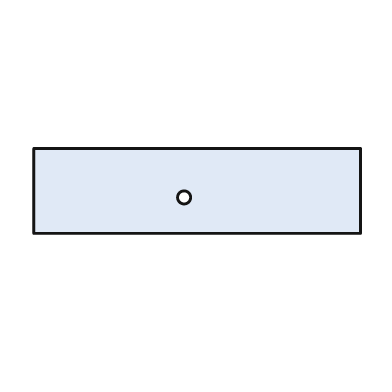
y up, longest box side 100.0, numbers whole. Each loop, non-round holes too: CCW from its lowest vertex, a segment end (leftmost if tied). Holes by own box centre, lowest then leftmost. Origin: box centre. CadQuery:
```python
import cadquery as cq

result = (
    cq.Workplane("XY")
    .moveTo(-50.0, -13.0)
    .lineTo(50.0, -13.0)
    .lineTo(50.0, 13.0)
    .lineTo(-50.0, 13.0)
    .close()
    .moveTo(-4.0, -2.0)
    .circle(2.0)
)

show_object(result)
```